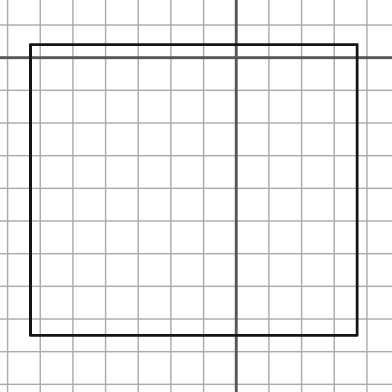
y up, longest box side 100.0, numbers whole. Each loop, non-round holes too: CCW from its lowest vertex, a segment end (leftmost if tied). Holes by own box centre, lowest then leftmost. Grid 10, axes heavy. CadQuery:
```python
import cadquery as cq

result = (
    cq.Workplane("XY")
    .moveTo(-63.0, -85.0)
    .lineTo(37.0, -85.0)
    .lineTo(37.0, 4.0)
    .lineTo(-63.0, 4.0)
    .close()
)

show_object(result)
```